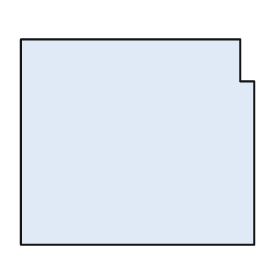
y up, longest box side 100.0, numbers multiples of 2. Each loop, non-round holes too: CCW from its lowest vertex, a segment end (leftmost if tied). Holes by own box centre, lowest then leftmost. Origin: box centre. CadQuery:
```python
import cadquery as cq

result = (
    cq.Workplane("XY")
    .moveTo(-50.0, -44.0)
    .lineTo(50.0, -44.0)
    .lineTo(50.0, 26.0)
    .lineTo(44.0, 26.0)
    .lineTo(44.0, 44.0)
    .lineTo(-50.0, 44.0)
    .close()
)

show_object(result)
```